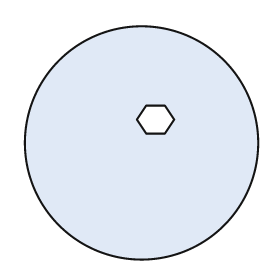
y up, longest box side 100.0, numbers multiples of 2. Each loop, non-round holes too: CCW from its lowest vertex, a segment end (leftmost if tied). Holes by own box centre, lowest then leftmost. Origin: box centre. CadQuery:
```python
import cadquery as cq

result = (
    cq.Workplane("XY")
    .moveTo(0.0, 0.0)
    .circle(50.0)
    .moveTo(2.0, 4.0)
    .lineTo(10.0, 4.0)
    .lineTo(14.0, 10.0)
    .lineTo(10.0, 16.0)
    .lineTo(2.0, 16.0)
    .lineTo(-2.0, 10.0)
    .close()
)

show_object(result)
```